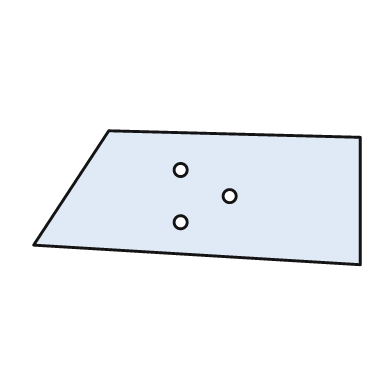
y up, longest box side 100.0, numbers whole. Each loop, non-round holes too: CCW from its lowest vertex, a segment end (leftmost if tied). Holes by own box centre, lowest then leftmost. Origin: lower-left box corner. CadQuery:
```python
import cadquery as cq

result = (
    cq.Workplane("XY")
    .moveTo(100.0, 0.0)
    .lineTo(100.0, 39.0)
    .lineTo(23.0, 41.0)
    .lineTo(0.0, 6.0)
    .close()
    .moveTo(45.0, 13.0)
    .circle(2.0)
    .moveTo(60.0, 21.0)
    .circle(2.0)
    .moveTo(45.0, 29.0)
    .circle(2.0)
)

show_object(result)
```